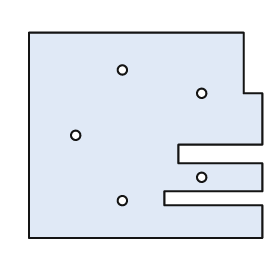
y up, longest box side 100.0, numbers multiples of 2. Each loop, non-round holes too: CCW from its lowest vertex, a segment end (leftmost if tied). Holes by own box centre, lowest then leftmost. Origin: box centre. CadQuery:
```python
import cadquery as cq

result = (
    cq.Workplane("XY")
    .moveTo(-50.0, -44.0)
    .lineTo(50.0, -44.0)
    .lineTo(50.0, -30.0)
    .lineTo(8.0, -30.0)
    .lineTo(8.0, -24.0)
    .lineTo(50.0, -24.0)
    .lineTo(50.0, -12.0)
    .lineTo(14.0, -12.0)
    .lineTo(14.0, -4.0)
    .lineTo(50.0, -4.0)
    .lineTo(50.0, 18.0)
    .lineTo(42.0, 18.0)
    .lineTo(42.0, 44.0)
    .lineTo(-50.0, 44.0)
    .close()
    .moveTo(-10.0, -28.0)
    .circle(2.0)
    .moveTo(24.0, -18.0)
    .circle(2.0)
    .moveTo(-30.0, 0.0)
    .circle(2.0)
    .moveTo(24.0, 18.0)
    .circle(2.0)
    .moveTo(-10.0, 28.0)
    .circle(2.0)
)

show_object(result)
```